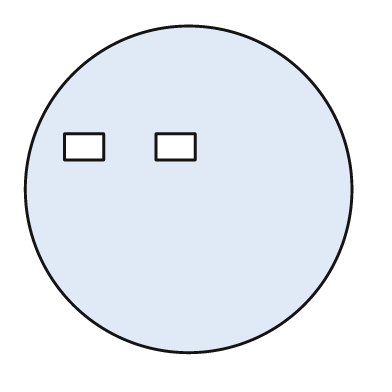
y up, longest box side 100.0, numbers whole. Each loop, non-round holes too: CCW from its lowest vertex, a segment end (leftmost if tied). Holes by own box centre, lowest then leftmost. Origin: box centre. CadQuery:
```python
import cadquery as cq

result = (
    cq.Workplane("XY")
    .moveTo(0.0, 0.0)
    .circle(50.0)
    .moveTo(-38.0, 9.0)
    .lineTo(-26.0, 9.0)
    .lineTo(-26.0, 17.0)
    .lineTo(-38.0, 17.0)
    .close()
    .moveTo(-10.0, 9.0)
    .lineTo(2.0, 9.0)
    .lineTo(2.0, 17.0)
    .lineTo(-10.0, 17.0)
    .close()
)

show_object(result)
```